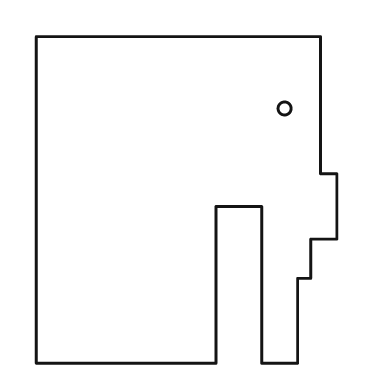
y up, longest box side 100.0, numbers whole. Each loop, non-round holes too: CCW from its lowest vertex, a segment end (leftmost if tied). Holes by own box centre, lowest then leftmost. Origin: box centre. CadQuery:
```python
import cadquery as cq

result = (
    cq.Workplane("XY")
    .moveTo(-46.0, -50.0)
    .lineTo(9.0, -50.0)
    .lineTo(9.0, -2.0)
    .lineTo(23.0, -2.0)
    .lineTo(23.0, -50.0)
    .lineTo(34.0, -50.0)
    .lineTo(34.0, -24.0)
    .lineTo(38.0, -24.0)
    .lineTo(38.0, -12.0)
    .lineTo(46.0, -12.0)
    .lineTo(46.0, 8.0)
    .lineTo(41.0, 8.0)
    .lineTo(41.0, 50.0)
    .lineTo(-46.0, 50.0)
    .close()
    .moveTo(30.0, 28.0)
    .circle(2.0)
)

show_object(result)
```